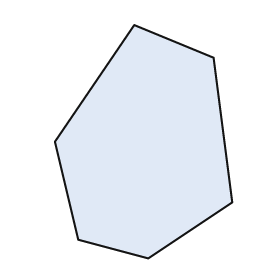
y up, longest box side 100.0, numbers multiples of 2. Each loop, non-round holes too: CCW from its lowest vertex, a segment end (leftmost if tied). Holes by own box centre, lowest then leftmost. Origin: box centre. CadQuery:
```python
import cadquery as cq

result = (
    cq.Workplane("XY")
    .moveTo(2.0, -50.0)
    .lineTo(38.0, -26.0)
    .lineTo(30.0, 36.0)
    .lineTo(-4.0, 50.0)
    .lineTo(-38.0, 0.0)
    .lineTo(-28.0, -42.0)
    .close()
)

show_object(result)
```